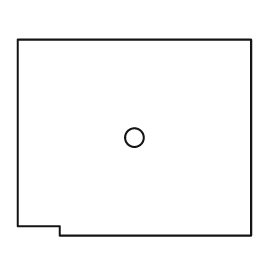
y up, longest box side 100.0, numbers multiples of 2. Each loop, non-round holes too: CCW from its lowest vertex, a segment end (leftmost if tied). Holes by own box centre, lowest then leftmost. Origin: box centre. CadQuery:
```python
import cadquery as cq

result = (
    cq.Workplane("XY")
    .moveTo(-32.0, -42.0)
    .lineTo(50.0, -42.0)
    .lineTo(50.0, 42.0)
    .lineTo(-50.0, 42.0)
    .lineTo(-50.0, -38.0)
    .lineTo(-32.0, -38.0)
    .close()
    .moveTo(0.0, 0.0)
    .circle(4.0)
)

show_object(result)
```